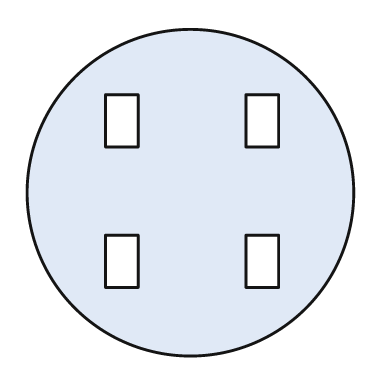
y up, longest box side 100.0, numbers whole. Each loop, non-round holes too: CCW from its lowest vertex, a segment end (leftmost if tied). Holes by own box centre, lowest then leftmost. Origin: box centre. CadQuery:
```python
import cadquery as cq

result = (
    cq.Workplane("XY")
    .moveTo(0.0, 0.0)
    .circle(50.0)
    .moveTo(-26.0, -29.0)
    .lineTo(-16.0, -29.0)
    .lineTo(-16.0, -13.0)
    .lineTo(-26.0, -13.0)
    .close()
    .moveTo(17.0, -29.0)
    .lineTo(27.0, -29.0)
    .lineTo(27.0, -13.0)
    .lineTo(17.0, -13.0)
    .close()
    .moveTo(-26.0, 14.0)
    .lineTo(-16.0, 14.0)
    .lineTo(-16.0, 30.0)
    .lineTo(-26.0, 30.0)
    .close()
    .moveTo(17.0, 14.0)
    .lineTo(27.0, 14.0)
    .lineTo(27.0, 30.0)
    .lineTo(17.0, 30.0)
    .close()
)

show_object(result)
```